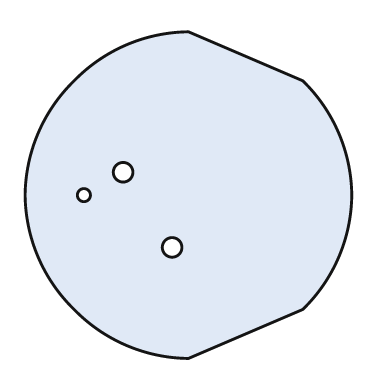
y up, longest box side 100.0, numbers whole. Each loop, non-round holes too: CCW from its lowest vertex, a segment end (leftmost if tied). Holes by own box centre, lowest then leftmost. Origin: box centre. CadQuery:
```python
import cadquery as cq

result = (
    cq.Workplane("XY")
    .moveTo(0.0, -50.0)
    .lineTo(35.0, -35.0)
    .threePointArc((46.0, -19.0), (50.0, 0.0))
    .threePointArc((46.0, 19.0), (35.0, 35.0))
    .lineTo(0.0, 50.0)
    .threePointArc((-19.0, 46.0), (-35.0, 35.0))
    .threePointArc((-46.0, 19.0), (-50.0, 0.0))
    .threePointArc((-46.0, -19.0), (-35.0, -35.0))
    .threePointArc((-19.0, -46.0), (0.0, -50.0))
    .close()
    .moveTo(-5.0, -16.0)
    .circle(3.0)
    .moveTo(-32.0, 0.0)
    .circle(2.0)
    .moveTo(-20.0, 7.0)
    .circle(3.0)
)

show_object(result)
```